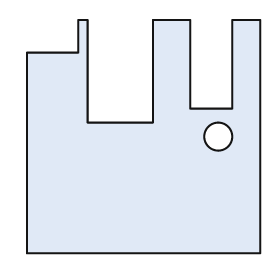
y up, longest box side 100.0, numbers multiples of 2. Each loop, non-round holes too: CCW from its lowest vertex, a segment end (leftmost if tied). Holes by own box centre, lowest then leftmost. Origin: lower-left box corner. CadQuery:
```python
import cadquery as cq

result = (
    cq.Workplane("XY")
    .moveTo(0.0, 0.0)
    .lineTo(100.0, 0.0)
    .lineTo(100.0, 100.0)
    .lineTo(88.0, 100.0)
    .lineTo(88.0, 62.0)
    .lineTo(70.0, 62.0)
    .lineTo(70.0, 100.0)
    .lineTo(54.0, 100.0)
    .lineTo(54.0, 56.0)
    .lineTo(26.0, 56.0)
    .lineTo(26.0, 100.0)
    .lineTo(22.0, 100.0)
    .lineTo(22.0, 86.0)
    .lineTo(0.0, 86.0)
    .close()
    .moveTo(82.0, 50.0)
    .circle(6.0)
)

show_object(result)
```